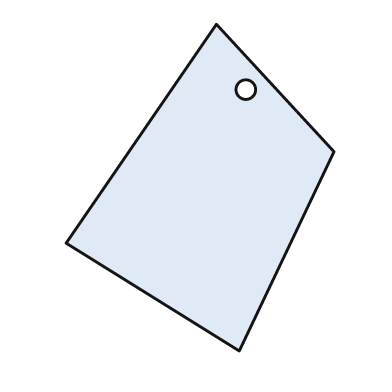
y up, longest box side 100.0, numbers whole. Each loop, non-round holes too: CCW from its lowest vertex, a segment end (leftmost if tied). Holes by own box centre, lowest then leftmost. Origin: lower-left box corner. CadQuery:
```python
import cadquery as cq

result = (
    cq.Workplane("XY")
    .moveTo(53.0, 0.0)
    .lineTo(82.0, 61.0)
    .lineTo(46.0, 100.0)
    .lineTo(0.0, 33.0)
    .close()
    .moveTo(55.0, 80.0)
    .circle(3.0)
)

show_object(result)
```